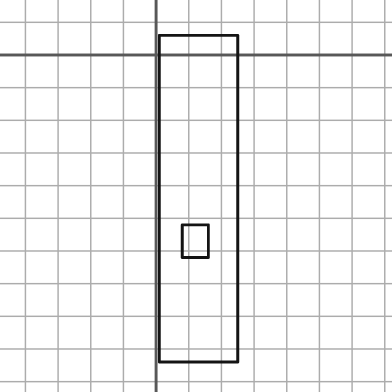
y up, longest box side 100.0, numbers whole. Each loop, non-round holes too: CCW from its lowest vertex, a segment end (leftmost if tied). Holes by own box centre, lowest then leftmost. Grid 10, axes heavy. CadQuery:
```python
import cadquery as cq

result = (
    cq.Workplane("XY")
    .moveTo(1.0, -94.0)
    .lineTo(25.0, -94.0)
    .lineTo(25.0, 6.0)
    .lineTo(1.0, 6.0)
    .close()
    .moveTo(8.0, -62.0)
    .lineTo(16.0, -62.0)
    .lineTo(16.0, -52.0)
    .lineTo(8.0, -52.0)
    .close()
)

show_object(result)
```